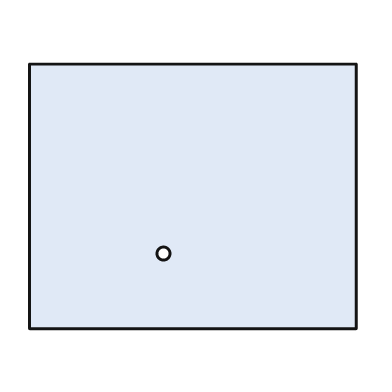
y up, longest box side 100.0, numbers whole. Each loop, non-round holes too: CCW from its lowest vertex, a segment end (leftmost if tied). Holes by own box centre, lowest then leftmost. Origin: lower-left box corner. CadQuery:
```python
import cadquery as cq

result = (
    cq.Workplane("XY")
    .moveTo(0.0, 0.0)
    .lineTo(100.0, 0.0)
    .lineTo(100.0, 81.0)
    .lineTo(0.0, 81.0)
    .close()
    .moveTo(41.0, 23.0)
    .circle(2.0)
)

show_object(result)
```